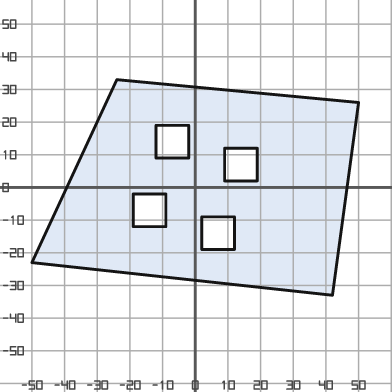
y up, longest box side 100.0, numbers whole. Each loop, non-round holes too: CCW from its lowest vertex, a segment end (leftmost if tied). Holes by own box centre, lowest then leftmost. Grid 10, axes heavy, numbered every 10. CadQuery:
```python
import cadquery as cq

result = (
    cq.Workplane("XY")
    .moveTo(42.0, -33.0)
    .lineTo(50.0, 26.0)
    .lineTo(-24.0, 33.0)
    .lineTo(-50.0, -23.0)
    .close()
    .moveTo(2.0, -19.0)
    .lineTo(12.0, -19.0)
    .lineTo(12.0, -9.0)
    .lineTo(2.0, -9.0)
    .close()
    .moveTo(-19.0, -12.0)
    .lineTo(-9.0, -12.0)
    .lineTo(-9.0, -2.0)
    .lineTo(-19.0, -2.0)
    .close()
    .moveTo(9.0, 2.0)
    .lineTo(19.0, 2.0)
    .lineTo(19.0, 12.0)
    .lineTo(9.0, 12.0)
    .close()
    .moveTo(-12.0, 9.0)
    .lineTo(-2.0, 9.0)
    .lineTo(-2.0, 19.0)
    .lineTo(-12.0, 19.0)
    .close()
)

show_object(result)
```